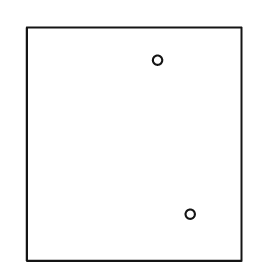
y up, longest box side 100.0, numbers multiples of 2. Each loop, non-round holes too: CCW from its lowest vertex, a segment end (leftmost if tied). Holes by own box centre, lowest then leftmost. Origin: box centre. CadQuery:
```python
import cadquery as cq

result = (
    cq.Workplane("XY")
    .moveTo(-46.0, -50.0)
    .lineTo(46.0, -50.0)
    .lineTo(46.0, 50.0)
    .lineTo(-46.0, 50.0)
    .close()
    .moveTo(24.0, -30.0)
    .circle(2.0)
    .moveTo(10.0, 36.0)
    .circle(2.0)
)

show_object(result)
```